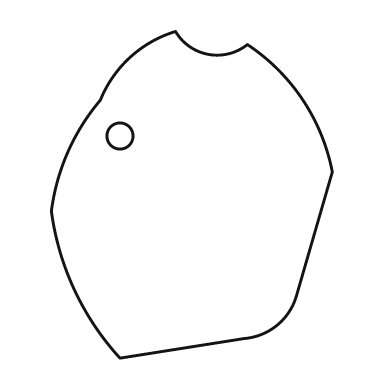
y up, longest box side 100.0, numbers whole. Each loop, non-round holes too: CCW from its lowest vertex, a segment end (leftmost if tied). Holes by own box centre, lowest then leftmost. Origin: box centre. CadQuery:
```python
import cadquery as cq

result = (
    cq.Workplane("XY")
    .moveTo(-22.0, -50.0)
    .lineTo(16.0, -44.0)
    .threePointArc((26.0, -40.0), (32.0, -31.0))
    .lineTo(43.0, 7.0)
    .threePointArc((34.0, 29.0), (17.0, 46.0))
    .threePointArc((5.0, 43.0), (-5.0, 50.0))
    .threePointArc((-19.0, 42.0), (-28.0, 29.0))
    .threePointArc((-38.0, 13.0), (-43.0, -5.0))
    .threePointArc((-36.0, -29.0), (-22.0, -50.0))
    .close()
    .moveTo(-22.0, 18.0)
    .circle(4.0)
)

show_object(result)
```